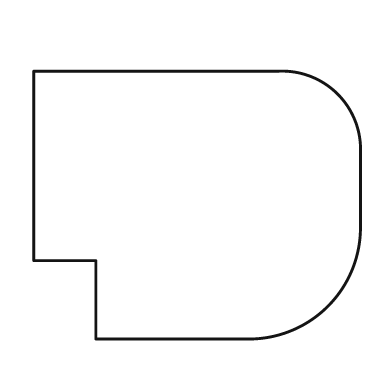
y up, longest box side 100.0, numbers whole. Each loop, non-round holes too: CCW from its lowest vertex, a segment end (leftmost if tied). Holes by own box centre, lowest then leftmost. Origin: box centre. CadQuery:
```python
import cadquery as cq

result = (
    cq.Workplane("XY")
    .moveTo(-31.0, -41.0)
    .lineTo(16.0, -41.0)
    .threePointArc((40.0, -31.0), (50.0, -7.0))
    .lineTo(50.0, 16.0)
    .threePointArc((43.0, 34.0), (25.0, 41.0))
    .lineTo(-50.0, 41.0)
    .lineTo(-50.0, -17.0)
    .lineTo(-31.0, -17.0)
    .close()
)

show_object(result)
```